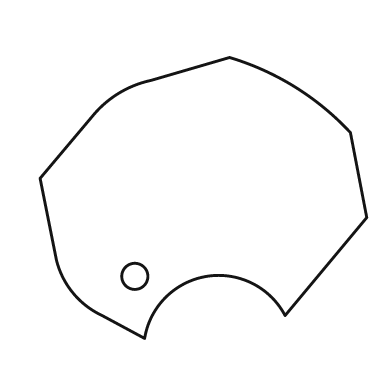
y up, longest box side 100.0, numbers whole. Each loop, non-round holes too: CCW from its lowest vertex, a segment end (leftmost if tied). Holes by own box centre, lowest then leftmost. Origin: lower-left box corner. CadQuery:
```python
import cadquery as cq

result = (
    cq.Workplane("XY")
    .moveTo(32.0, 0.0)
    .threePointArc((51.0, 19.0), (75.0, 7.0))
    .lineTo(100.0, 37.0)
    .lineTo(95.0, 63.0)
    .threePointArc((78.0, 77.0), (58.0, 86.0))
    .lineTo(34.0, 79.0)
    .threePointArc((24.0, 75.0), (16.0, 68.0))
    .lineTo(0.0, 49.0)
    .lineTo(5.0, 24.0)
    .threePointArc((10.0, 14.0), (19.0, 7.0))
    .close()
    .moveTo(29.0, 19.0)
    .circle(4.0)
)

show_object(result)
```